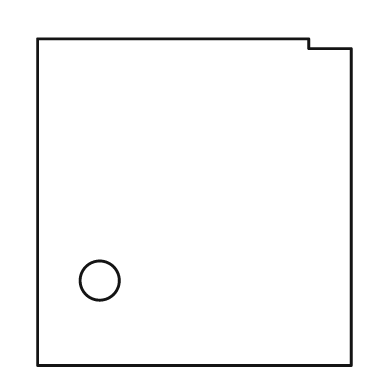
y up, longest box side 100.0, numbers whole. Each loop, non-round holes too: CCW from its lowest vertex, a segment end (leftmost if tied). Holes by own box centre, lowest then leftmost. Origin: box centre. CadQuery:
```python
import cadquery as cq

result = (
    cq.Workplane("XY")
    .moveTo(-48.0, -50.0)
    .lineTo(48.0, -50.0)
    .lineTo(48.0, 47.0)
    .lineTo(35.0, 47.0)
    .lineTo(35.0, 50.0)
    .lineTo(-48.0, 50.0)
    .close()
    .moveTo(-29.0, -24.0)
    .circle(6.0)
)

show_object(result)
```